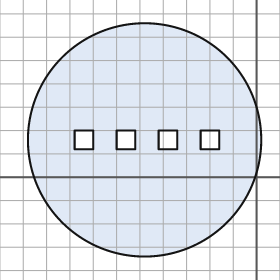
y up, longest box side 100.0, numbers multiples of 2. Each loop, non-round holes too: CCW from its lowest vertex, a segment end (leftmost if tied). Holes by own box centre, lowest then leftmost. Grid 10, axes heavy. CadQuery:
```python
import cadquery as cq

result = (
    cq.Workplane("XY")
    .moveTo(-48.0, 16.0)
    .circle(50.0)
    .moveTo(-78.0, 12.0)
    .lineTo(-70.0, 12.0)
    .lineTo(-70.0, 20.0)
    .lineTo(-78.0, 20.0)
    .close()
    .moveTo(-60.0, 12.0)
    .lineTo(-52.0, 12.0)
    .lineTo(-52.0, 20.0)
    .lineTo(-60.0, 20.0)
    .close()
    .moveTo(-42.0, 12.0)
    .lineTo(-34.0, 12.0)
    .lineTo(-34.0, 20.0)
    .lineTo(-42.0, 20.0)
    .close()
    .moveTo(-24.0, 12.0)
    .lineTo(-16.0, 12.0)
    .lineTo(-16.0, 20.0)
    .lineTo(-24.0, 20.0)
    .close()
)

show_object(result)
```